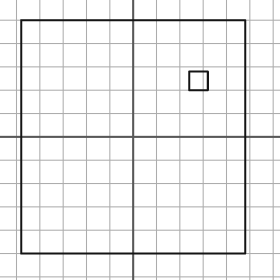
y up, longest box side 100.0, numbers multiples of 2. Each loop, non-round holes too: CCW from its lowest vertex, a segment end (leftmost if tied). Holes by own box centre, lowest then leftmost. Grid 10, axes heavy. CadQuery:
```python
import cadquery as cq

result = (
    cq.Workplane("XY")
    .moveTo(-48.0, -50.0)
    .lineTo(48.0, -50.0)
    .lineTo(48.0, 50.0)
    .lineTo(-48.0, 50.0)
    .close()
    .moveTo(24.0, 20.0)
    .lineTo(32.0, 20.0)
    .lineTo(32.0, 28.0)
    .lineTo(24.0, 28.0)
    .close()
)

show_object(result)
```